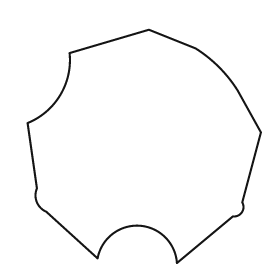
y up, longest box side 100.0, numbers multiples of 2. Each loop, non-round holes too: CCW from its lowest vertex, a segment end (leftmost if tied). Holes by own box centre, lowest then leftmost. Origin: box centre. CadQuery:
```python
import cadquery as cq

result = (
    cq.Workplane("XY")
    .moveTo(14.0, -50.0)
    .lineTo(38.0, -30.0)
    .threePointArc((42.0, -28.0), (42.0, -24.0))
    .lineTo(50.0, 6.0)
    .lineTo(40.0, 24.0)
    .threePointArc((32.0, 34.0), (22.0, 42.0))
    .lineTo(2.0, 50.0)
    .lineTo(-32.0, 40.0)
    .threePointArc((-36.0, 22.0), (-50.0, 10.0))
    .lineTo(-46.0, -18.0)
    .threePointArc((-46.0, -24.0), (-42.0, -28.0))
    .lineTo(-20.0, -48.0)
    .threePointArc((-2.0, -34.0), (14.0, -50.0))
    .close()
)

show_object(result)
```